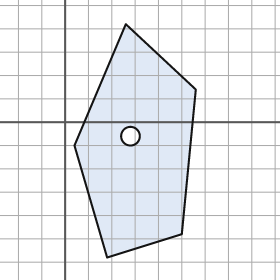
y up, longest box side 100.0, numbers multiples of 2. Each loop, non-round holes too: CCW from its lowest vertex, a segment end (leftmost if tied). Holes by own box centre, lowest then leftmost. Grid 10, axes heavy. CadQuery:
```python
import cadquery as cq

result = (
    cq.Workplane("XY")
    .moveTo(18.0, -58.0)
    .lineTo(50.0, -48.0)
    .lineTo(56.0, 14.0)
    .lineTo(26.0, 42.0)
    .lineTo(4.0, -10.0)
    .close()
    .moveTo(28.0, -6.0)
    .circle(4.0)
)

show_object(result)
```